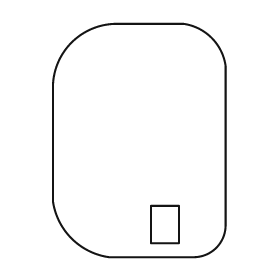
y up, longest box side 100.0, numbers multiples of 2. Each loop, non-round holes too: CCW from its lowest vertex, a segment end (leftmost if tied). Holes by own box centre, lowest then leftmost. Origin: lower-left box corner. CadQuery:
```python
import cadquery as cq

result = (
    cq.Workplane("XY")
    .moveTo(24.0, 0.0)
    .lineTo(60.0, 0.0)
    .threePointArc((70.0, 4.0), (74.0, 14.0))
    .lineTo(74.0, 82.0)
    .threePointArc((68.0, 94.0), (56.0, 100.0))
    .lineTo(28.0, 100.0)
    .threePointArc((8.0, 92.0), (0.0, 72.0))
    .lineTo(0.0, 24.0)
    .threePointArc((8.0, 8.0), (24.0, 0.0))
    .close()
    .moveTo(42.0, 6.0)
    .lineTo(54.0, 6.0)
    .lineTo(54.0, 22.0)
    .lineTo(42.0, 22.0)
    .close()
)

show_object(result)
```